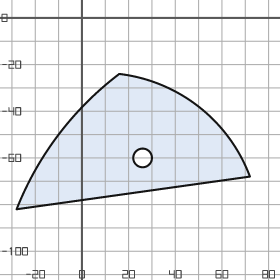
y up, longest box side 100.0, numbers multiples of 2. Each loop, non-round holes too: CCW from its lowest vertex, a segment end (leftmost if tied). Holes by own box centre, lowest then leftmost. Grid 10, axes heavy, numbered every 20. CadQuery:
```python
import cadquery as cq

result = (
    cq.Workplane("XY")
    .moveTo(-28.0, -82.0)
    .lineTo(72.0, -68.0)
    .threePointArc((50.0, -38.0), (16.0, -24.0))
    .threePointArc((-10.0, -50.0), (-28.0, -82.0))
    .close()
    .moveTo(26.0, -60.0)
    .circle(4.0)
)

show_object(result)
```